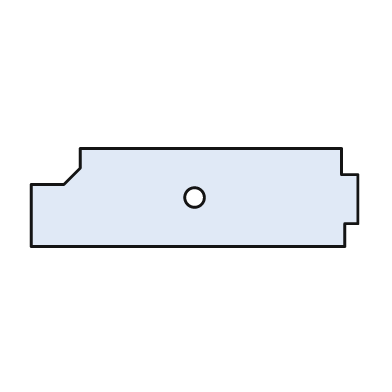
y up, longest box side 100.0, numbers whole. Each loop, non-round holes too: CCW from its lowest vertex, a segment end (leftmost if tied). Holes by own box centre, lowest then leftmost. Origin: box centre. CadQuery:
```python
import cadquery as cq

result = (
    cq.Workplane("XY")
    .moveTo(-50.0, -15.0)
    .lineTo(46.0, -15.0)
    .lineTo(46.0, -8.0)
    .lineTo(50.0, -8.0)
    .lineTo(50.0, 7.0)
    .lineTo(45.0, 7.0)
    .lineTo(45.0, 15.0)
    .lineTo(-35.0, 15.0)
    .lineTo(-35.0, 9.0)
    .lineTo(-40.0, 4.0)
    .lineTo(-50.0, 4.0)
    .close()
    .moveTo(0.0, 0.0)
    .circle(3.0)
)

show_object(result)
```